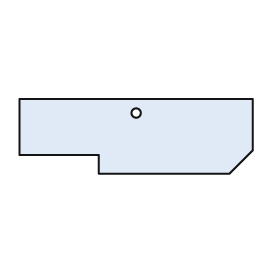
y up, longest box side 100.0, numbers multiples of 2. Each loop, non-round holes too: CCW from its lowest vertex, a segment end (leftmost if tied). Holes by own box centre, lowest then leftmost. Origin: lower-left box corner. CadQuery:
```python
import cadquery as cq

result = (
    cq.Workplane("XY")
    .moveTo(34.0, 0.0)
    .lineTo(90.0, 0.0)
    .lineTo(100.0, 10.0)
    .lineTo(100.0, 32.0)
    .lineTo(0.0, 32.0)
    .lineTo(0.0, 8.0)
    .lineTo(34.0, 8.0)
    .close()
    .moveTo(50.0, 26.0)
    .circle(2.0)
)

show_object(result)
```